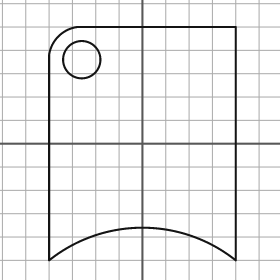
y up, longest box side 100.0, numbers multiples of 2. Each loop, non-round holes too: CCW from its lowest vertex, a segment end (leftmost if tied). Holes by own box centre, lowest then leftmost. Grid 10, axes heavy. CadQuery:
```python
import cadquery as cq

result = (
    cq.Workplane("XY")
    .moveTo(-40.0, -50.0)
    .threePointArc((0.0, -36.0), (40.0, -50.0))
    .lineTo(40.0, 50.0)
    .lineTo(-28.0, 50.0)
    .threePointArc((-36.0, 46.0), (-40.0, 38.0))
    .close()
    .moveTo(-26.0, 36.0)
    .circle(8.0)
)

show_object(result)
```